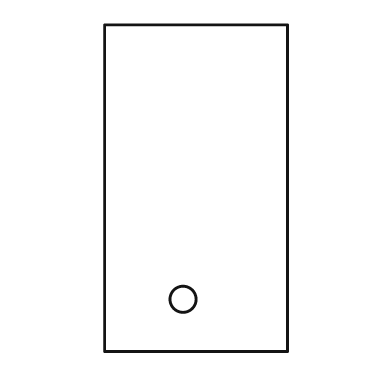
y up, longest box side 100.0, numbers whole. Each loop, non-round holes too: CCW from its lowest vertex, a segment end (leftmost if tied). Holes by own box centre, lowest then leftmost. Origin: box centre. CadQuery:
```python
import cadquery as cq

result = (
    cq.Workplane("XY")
    .moveTo(-28.0, -50.0)
    .lineTo(28.0, -50.0)
    .lineTo(28.0, 50.0)
    .lineTo(-28.0, 50.0)
    .close()
    .moveTo(-4.0, -34.0)
    .circle(4.0)
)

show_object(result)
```